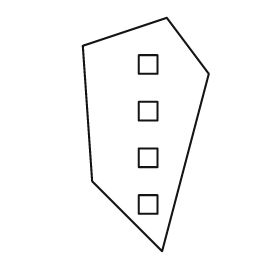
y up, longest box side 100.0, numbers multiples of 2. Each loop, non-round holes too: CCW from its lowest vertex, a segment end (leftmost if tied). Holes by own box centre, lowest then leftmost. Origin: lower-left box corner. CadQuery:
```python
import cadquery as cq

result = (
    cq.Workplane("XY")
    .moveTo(34.0, 0.0)
    .lineTo(54.0, 76.0)
    .lineTo(36.0, 100.0)
    .lineTo(0.0, 88.0)
    .lineTo(4.0, 30.0)
    .close()
    .moveTo(24.0, 16.0)
    .lineTo(32.0, 16.0)
    .lineTo(32.0, 24.0)
    .lineTo(24.0, 24.0)
    .close()
    .moveTo(24.0, 36.0)
    .lineTo(32.0, 36.0)
    .lineTo(32.0, 44.0)
    .lineTo(24.0, 44.0)
    .close()
    .moveTo(24.0, 56.0)
    .lineTo(32.0, 56.0)
    .lineTo(32.0, 64.0)
    .lineTo(24.0, 64.0)
    .close()
    .moveTo(24.0, 76.0)
    .lineTo(32.0, 76.0)
    .lineTo(32.0, 84.0)
    .lineTo(24.0, 84.0)
    .close()
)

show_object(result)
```